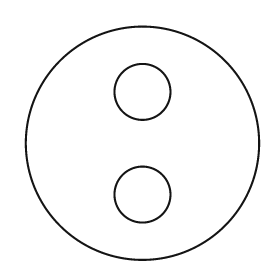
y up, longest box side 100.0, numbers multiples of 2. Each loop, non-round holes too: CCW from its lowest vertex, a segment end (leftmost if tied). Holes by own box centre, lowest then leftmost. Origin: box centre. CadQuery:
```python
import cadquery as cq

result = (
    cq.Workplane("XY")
    .moveTo(0.0, 0.0)
    .circle(50.0)
    .moveTo(0.0, -22.0)
    .circle(12.0)
    .moveTo(0.0, 22.0)
    .circle(12.0)
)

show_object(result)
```